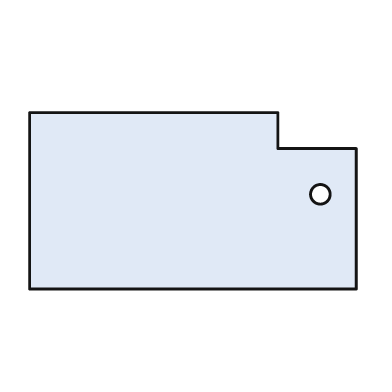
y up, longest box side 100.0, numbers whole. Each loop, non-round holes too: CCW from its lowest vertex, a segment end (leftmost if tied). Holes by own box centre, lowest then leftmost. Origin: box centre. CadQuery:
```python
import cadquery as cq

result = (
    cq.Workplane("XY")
    .moveTo(-50.0, -27.0)
    .lineTo(50.0, -27.0)
    .lineTo(50.0, 16.0)
    .lineTo(26.0, 16.0)
    .lineTo(26.0, 27.0)
    .lineTo(-50.0, 27.0)
    .close()
    .moveTo(39.0, 2.0)
    .circle(3.0)
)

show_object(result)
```